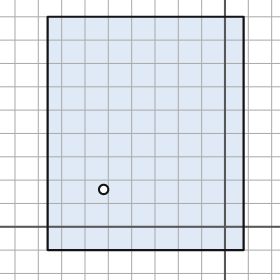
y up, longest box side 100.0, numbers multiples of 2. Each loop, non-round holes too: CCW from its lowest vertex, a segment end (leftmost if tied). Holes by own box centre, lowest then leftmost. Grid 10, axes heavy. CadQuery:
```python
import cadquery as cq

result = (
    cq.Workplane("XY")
    .moveTo(-76.0, -10.0)
    .lineTo(8.0, -10.0)
    .lineTo(8.0, 90.0)
    .lineTo(-76.0, 90.0)
    .close()
    .moveTo(-52.0, 16.0)
    .circle(2.0)
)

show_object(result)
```